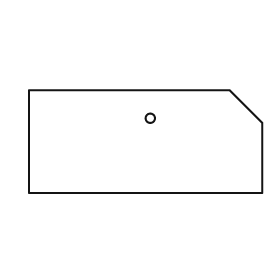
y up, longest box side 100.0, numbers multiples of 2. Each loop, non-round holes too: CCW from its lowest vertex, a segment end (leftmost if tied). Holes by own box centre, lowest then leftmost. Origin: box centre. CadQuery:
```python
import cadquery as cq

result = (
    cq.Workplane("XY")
    .moveTo(-50.0, -22.0)
    .lineTo(50.0, -22.0)
    .lineTo(50.0, 8.0)
    .lineTo(36.0, 22.0)
    .lineTo(-50.0, 22.0)
    .close()
    .moveTo(2.0, 10.0)
    .circle(2.0)
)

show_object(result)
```